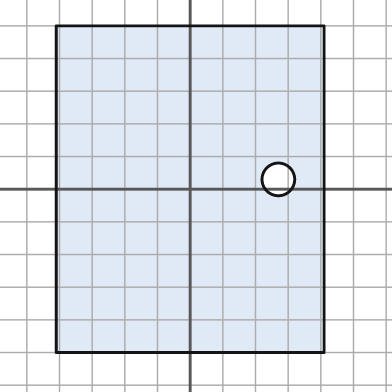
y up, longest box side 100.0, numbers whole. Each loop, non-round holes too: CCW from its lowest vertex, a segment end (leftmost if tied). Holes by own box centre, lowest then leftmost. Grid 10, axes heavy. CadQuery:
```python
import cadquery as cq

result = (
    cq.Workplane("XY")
    .moveTo(-41.0, -50.0)
    .lineTo(41.0, -50.0)
    .lineTo(41.0, 50.0)
    .lineTo(-41.0, 50.0)
    .close()
    .moveTo(27.0, 3.0)
    .circle(5.0)
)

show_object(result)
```